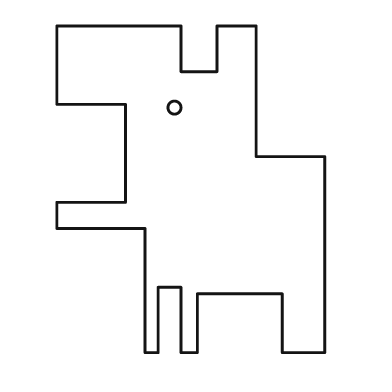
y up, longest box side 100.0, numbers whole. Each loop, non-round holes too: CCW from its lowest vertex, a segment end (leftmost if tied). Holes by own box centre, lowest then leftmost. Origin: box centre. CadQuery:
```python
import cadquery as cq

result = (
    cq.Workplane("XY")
    .moveTo(-14.0, -50.0)
    .lineTo(-10.0, -50.0)
    .lineTo(-10.0, -30.0)
    .lineTo(-3.0, -30.0)
    .lineTo(-3.0, -50.0)
    .lineTo(2.0, -50.0)
    .lineTo(2.0, -32.0)
    .lineTo(28.0, -32.0)
    .lineTo(28.0, -50.0)
    .lineTo(41.0, -50.0)
    .lineTo(41.0, 10.0)
    .lineTo(20.0, 10.0)
    .lineTo(20.0, 50.0)
    .lineTo(8.0, 50.0)
    .lineTo(8.0, 36.0)
    .lineTo(-3.0, 36.0)
    .lineTo(-3.0, 50.0)
    .lineTo(-41.0, 50.0)
    .lineTo(-41.0, 26.0)
    .lineTo(-20.0, 26.0)
    .lineTo(-20.0, -4.0)
    .lineTo(-41.0, -4.0)
    .lineTo(-41.0, -12.0)
    .lineTo(-14.0, -12.0)
    .close()
    .moveTo(-5.0, 25.0)
    .circle(2.0)
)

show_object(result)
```